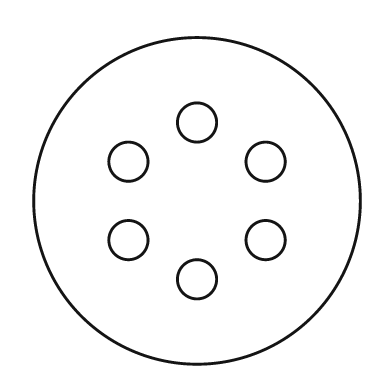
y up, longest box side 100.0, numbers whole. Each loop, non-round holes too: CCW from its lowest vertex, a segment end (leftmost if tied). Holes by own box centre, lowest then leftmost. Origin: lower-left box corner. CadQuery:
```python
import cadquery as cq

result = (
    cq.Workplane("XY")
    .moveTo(50.0, 50.0)
    .circle(50.0)
    .moveTo(50.0, 26.0)
    .circle(6.0)
    .moveTo(29.0, 38.0)
    .circle(6.0)
    .moveTo(71.0, 38.0)
    .circle(6.0)
    .moveTo(29.0, 62.0)
    .circle(6.0)
    .moveTo(71.0, 62.0)
    .circle(6.0)
    .moveTo(50.0, 74.0)
    .circle(6.0)
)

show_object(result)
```